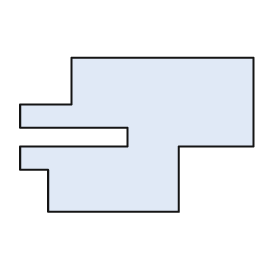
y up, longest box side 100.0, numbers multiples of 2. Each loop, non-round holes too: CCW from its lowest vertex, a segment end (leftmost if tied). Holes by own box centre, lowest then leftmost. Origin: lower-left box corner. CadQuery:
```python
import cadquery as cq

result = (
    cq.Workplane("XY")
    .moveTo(12.0, 0.0)
    .lineTo(68.0, 0.0)
    .lineTo(68.0, 28.0)
    .lineTo(100.0, 28.0)
    .lineTo(100.0, 66.0)
    .lineTo(22.0, 66.0)
    .lineTo(22.0, 46.0)
    .lineTo(0.0, 46.0)
    .lineTo(0.0, 36.0)
    .lineTo(46.0, 36.0)
    .lineTo(46.0, 28.0)
    .lineTo(0.0, 28.0)
    .lineTo(0.0, 18.0)
    .lineTo(12.0, 18.0)
    .close()
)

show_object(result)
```